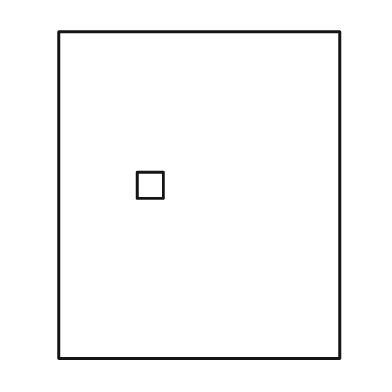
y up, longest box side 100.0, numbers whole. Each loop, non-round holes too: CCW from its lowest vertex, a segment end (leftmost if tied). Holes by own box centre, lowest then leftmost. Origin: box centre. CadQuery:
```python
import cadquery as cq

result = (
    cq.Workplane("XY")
    .moveTo(-43.0, -50.0)
    .lineTo(43.0, -50.0)
    .lineTo(43.0, 50.0)
    .lineTo(-43.0, 50.0)
    .close()
    .moveTo(-19.0, -1.0)
    .lineTo(-11.0, -1.0)
    .lineTo(-11.0, 7.0)
    .lineTo(-19.0, 7.0)
    .close()
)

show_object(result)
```